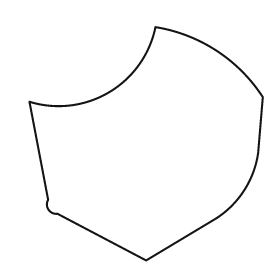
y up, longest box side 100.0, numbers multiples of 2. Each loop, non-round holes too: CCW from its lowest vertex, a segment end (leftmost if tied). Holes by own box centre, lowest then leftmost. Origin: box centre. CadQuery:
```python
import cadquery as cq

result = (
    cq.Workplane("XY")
    .moveTo(0.0, -50.0)
    .lineTo(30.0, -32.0)
    .threePointArc((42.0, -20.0), (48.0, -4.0))
    .lineTo(50.0, 20.0)
    .threePointArc((30.0, 40.0), (4.0, 50.0))
    .threePointArc((-16.0, 22.0), (-50.0, 18.0))
    .lineTo(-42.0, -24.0)
    .threePointArc((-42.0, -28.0), (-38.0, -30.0))
    .close()
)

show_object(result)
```